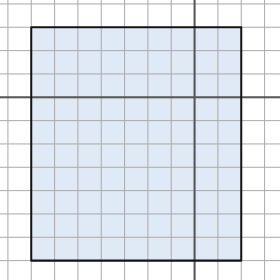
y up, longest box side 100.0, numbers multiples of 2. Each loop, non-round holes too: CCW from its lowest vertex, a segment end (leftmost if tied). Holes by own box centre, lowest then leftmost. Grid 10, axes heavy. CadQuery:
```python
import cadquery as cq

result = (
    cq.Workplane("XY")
    .moveTo(-70.0, -70.0)
    .lineTo(20.0, -70.0)
    .lineTo(20.0, 30.0)
    .lineTo(-70.0, 30.0)
    .close()
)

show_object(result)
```